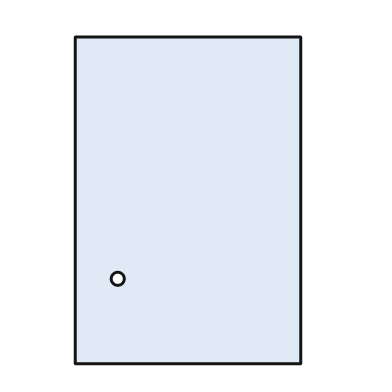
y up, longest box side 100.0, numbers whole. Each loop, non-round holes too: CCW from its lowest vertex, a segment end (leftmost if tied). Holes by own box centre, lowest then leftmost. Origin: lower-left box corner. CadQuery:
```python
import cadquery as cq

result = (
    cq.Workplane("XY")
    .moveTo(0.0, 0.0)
    .lineTo(69.0, 0.0)
    .lineTo(69.0, 100.0)
    .lineTo(0.0, 100.0)
    .close()
    .moveTo(13.0, 26.0)
    .circle(2.0)
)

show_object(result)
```